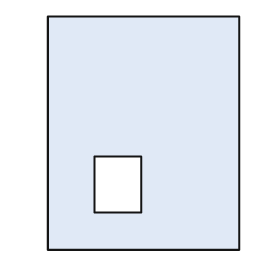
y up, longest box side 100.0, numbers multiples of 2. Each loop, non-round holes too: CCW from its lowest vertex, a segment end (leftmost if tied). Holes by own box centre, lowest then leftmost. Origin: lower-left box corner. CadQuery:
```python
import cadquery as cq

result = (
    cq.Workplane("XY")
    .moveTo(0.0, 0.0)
    .lineTo(82.0, 0.0)
    .lineTo(82.0, 100.0)
    .lineTo(0.0, 100.0)
    .close()
    .moveTo(20.0, 16.0)
    .lineTo(40.0, 16.0)
    .lineTo(40.0, 40.0)
    .lineTo(20.0, 40.0)
    .close()
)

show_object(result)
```